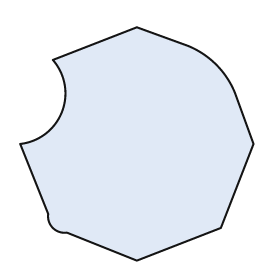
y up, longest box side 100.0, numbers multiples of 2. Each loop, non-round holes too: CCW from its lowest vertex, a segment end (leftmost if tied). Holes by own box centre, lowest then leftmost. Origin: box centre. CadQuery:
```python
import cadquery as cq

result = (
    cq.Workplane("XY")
    .moveTo(0.0, -50.0)
    .lineTo(36.0, -36.0)
    .lineTo(50.0, 0.0)
    .lineTo(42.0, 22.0)
    .threePointArc((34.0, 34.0), (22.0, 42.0))
    .lineTo(0.0, 50.0)
    .lineTo(-36.0, 36.0)
    .threePointArc((-32.0, 14.0), (-50.0, 0.0))
    .lineTo(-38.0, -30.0)
    .threePointArc((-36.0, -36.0), (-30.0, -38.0))
    .close()
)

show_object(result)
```